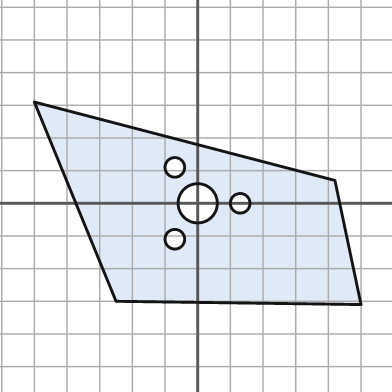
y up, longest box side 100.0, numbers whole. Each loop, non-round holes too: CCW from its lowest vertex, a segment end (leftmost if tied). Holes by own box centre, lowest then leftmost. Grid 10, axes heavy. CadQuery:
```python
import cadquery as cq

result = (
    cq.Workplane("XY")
    .moveTo(50.0, -31.0)
    .lineTo(42.0, 7.0)
    .lineTo(-50.0, 31.0)
    .lineTo(-25.0, -30.0)
    .close()
    .moveTo(-7.0, -11.0)
    .circle(3.0)
    .moveTo(0.0, 0.0)
    .circle(6.0)
    .moveTo(13.0, 0.0)
    .circle(3.0)
    .moveTo(-7.0, 11.0)
    .circle(3.0)
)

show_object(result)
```